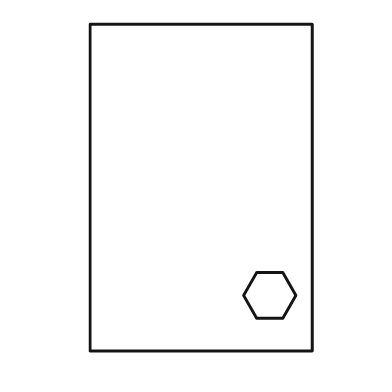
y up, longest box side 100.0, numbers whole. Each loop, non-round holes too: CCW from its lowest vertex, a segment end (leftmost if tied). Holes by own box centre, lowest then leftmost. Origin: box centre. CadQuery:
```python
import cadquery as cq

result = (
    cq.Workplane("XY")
    .moveTo(-34.0, -50.0)
    .lineTo(34.0, -50.0)
    .lineTo(34.0, 50.0)
    .lineTo(-34.0, 50.0)
    .close()
    .moveTo(17.0, -40.0)
    .lineTo(25.0, -40.0)
    .lineTo(29.0, -33.0)
    .lineTo(25.0, -26.0)
    .lineTo(17.0, -26.0)
    .lineTo(13.0, -33.0)
    .close()
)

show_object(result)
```